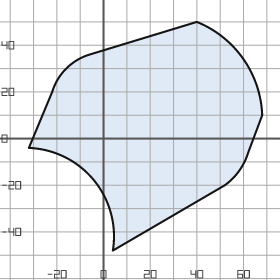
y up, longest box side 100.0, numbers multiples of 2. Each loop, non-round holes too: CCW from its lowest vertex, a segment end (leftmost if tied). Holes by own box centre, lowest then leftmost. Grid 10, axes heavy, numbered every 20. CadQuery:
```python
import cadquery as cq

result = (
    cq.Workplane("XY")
    .moveTo(4.0, -48.0)
    .lineTo(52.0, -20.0)
    .threePointArc((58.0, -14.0), (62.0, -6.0))
    .lineTo(68.0, 10.0)
    .threePointArc((60.0, 34.0), (40.0, 50.0))
    .lineTo(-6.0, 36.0)
    .threePointArc((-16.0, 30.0), (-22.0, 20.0))
    .lineTo(-32.0, -4.0)
    .threePointArc((-4.0, -18.0), (4.0, -48.0))
    .close()
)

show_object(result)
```